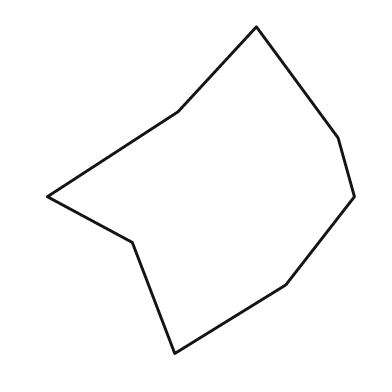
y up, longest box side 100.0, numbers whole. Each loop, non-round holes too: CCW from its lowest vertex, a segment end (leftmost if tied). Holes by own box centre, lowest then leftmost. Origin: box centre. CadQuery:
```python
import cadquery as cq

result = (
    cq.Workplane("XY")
    .moveTo(-8.0, -50.0)
    .lineTo(26.0, -29.0)
    .lineTo(47.0, -2.0)
    .lineTo(42.0, 16.0)
    .lineTo(17.0, 50.0)
    .lineTo(-7.0, 24.0)
    .lineTo(-47.0, -2.0)
    .lineTo(-21.0, -16.0)
    .close()
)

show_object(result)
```